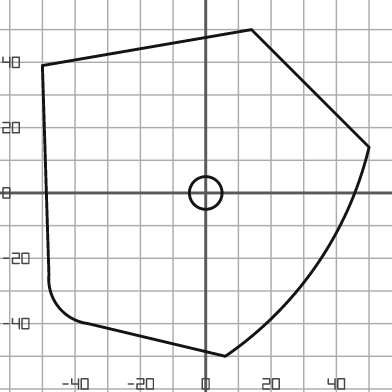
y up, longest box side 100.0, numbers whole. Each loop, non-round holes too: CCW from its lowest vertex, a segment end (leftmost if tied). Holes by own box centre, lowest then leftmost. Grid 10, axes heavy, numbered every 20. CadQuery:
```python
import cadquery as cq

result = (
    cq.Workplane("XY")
    .moveTo(6.0, -50.0)
    .threePointArc((34.0, -22.0), (50.0, 14.0))
    .lineTo(14.0, 50.0)
    .lineTo(-50.0, 39.0)
    .lineTo(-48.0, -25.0)
    .threePointArc((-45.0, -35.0), (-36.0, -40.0))
    .close()
    .moveTo(0.0, 0.0)
    .circle(5.0)
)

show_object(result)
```